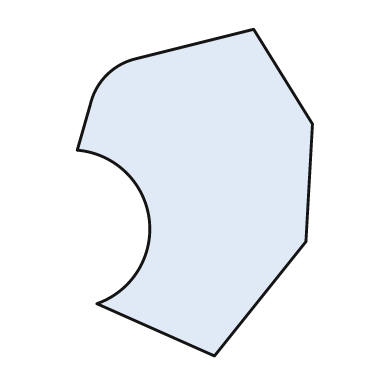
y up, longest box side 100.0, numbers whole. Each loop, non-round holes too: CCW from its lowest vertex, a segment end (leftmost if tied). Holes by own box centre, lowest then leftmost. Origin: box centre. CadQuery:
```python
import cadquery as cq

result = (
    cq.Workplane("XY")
    .moveTo(6.0, -50.0)
    .lineTo(34.0, -15.0)
    .lineTo(36.0, 21.0)
    .lineTo(18.0, 50.0)
    .lineTo(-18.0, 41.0)
    .threePointArc((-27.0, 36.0), (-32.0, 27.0))
    .lineTo(-36.0, 13.0)
    .threePointArc((-14.0, -8.0), (-30.0, -34.0))
    .close()
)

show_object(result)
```